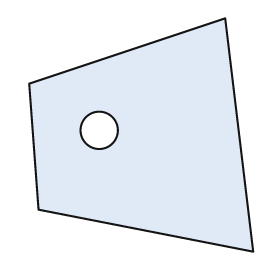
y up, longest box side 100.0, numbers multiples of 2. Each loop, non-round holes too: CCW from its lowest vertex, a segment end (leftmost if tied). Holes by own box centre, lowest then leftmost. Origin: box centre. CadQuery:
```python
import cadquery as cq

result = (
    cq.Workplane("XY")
    .moveTo(48.0, -50.0)
    .lineTo(36.0, 50.0)
    .lineTo(-48.0, 22.0)
    .lineTo(-44.0, -32.0)
    .close()
    .moveTo(-18.0, 2.0)
    .circle(8.0)
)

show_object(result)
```